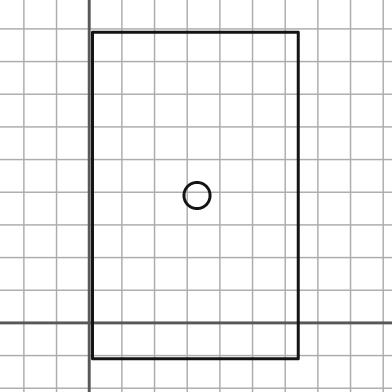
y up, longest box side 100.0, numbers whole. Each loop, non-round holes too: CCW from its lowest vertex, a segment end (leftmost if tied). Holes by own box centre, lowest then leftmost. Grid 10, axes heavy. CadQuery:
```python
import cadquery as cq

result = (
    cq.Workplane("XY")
    .moveTo(1.0, -11.0)
    .lineTo(64.0, -11.0)
    .lineTo(64.0, 89.0)
    .lineTo(1.0, 89.0)
    .close()
    .moveTo(33.0, 39.0)
    .circle(4.0)
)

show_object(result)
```